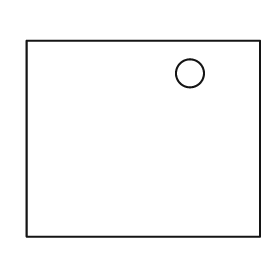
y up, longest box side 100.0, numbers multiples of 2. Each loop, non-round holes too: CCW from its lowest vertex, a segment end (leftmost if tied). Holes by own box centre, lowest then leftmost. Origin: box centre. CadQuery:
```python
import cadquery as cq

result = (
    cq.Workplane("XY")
    .moveTo(-50.0, -42.0)
    .lineTo(50.0, -42.0)
    .lineTo(50.0, 42.0)
    .lineTo(-50.0, 42.0)
    .close()
    .moveTo(20.0, 28.0)
    .circle(6.0)
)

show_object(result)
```